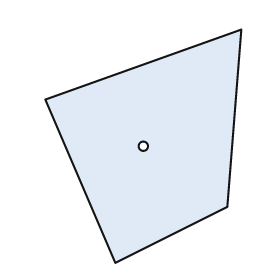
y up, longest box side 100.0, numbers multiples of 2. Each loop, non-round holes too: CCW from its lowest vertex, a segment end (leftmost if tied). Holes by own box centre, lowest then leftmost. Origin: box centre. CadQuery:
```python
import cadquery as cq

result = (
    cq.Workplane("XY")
    .moveTo(-12.0, -50.0)
    .lineTo(36.0, -26.0)
    .lineTo(42.0, 50.0)
    .lineTo(-42.0, 20.0)
    .close()
    .moveTo(0.0, 0.0)
    .circle(2.0)
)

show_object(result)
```